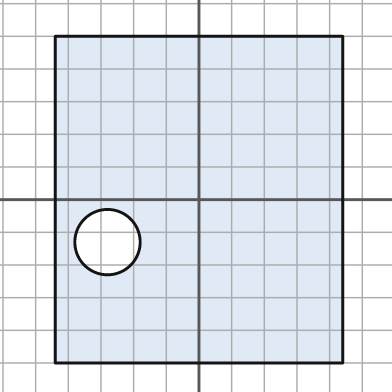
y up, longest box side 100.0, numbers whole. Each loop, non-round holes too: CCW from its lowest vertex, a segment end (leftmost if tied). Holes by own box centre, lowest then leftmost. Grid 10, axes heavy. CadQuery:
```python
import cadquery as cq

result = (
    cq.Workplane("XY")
    .moveTo(-44.0, -50.0)
    .lineTo(44.0, -50.0)
    .lineTo(44.0, 50.0)
    .lineTo(-44.0, 50.0)
    .close()
    .moveTo(-28.0, -13.0)
    .circle(10.0)
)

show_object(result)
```